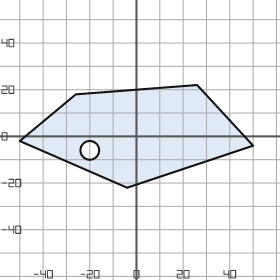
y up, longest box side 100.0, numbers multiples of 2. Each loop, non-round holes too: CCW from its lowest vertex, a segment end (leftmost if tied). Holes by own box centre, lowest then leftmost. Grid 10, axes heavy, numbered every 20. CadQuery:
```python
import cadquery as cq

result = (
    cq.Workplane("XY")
    .moveTo(-4.0, -22.0)
    .lineTo(50.0, -4.0)
    .lineTo(26.0, 22.0)
    .lineTo(-26.0, 18.0)
    .lineTo(-50.0, -2.0)
    .close()
    .moveTo(-20.0, -6.0)
    .circle(4.0)
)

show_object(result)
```